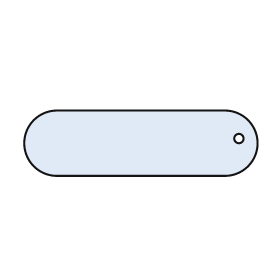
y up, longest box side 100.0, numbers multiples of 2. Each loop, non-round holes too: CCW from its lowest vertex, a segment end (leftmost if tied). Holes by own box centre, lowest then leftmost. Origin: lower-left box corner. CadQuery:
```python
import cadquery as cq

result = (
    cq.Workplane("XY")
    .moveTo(14.0, 0.0)
    .lineTo(86.0, 0.0)
    .threePointArc((100.0, 14.0), (86.0, 28.0))
    .lineTo(14.0, 28.0)
    .threePointArc((0.0, 14.0), (14.0, 0.0))
    .close()
    .moveTo(92.0, 16.0)
    .circle(2.0)
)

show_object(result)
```